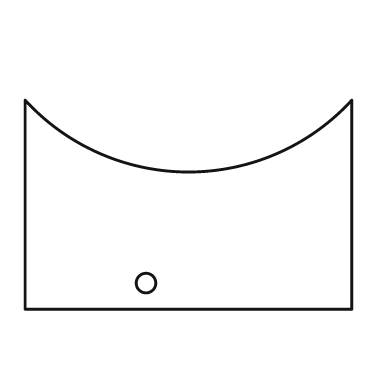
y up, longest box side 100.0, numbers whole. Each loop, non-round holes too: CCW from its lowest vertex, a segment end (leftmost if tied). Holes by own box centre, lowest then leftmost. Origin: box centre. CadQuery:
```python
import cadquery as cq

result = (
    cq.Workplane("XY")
    .moveTo(-50.0, -32.0)
    .lineTo(50.0, -32.0)
    .lineTo(50.0, 32.0)
    .threePointArc((0.0, 10.0), (-50.0, 32.0))
    .close()
    .moveTo(-13.0, -24.0)
    .circle(3.0)
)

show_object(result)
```